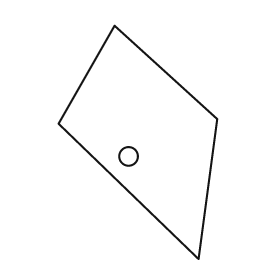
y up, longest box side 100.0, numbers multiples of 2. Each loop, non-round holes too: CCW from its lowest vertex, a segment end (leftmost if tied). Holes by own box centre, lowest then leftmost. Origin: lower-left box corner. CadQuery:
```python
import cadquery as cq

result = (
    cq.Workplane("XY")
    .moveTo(60.0, 0.0)
    .lineTo(68.0, 60.0)
    .lineTo(24.0, 100.0)
    .lineTo(0.0, 58.0)
    .close()
    .moveTo(30.0, 44.0)
    .circle(4.0)
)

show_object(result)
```